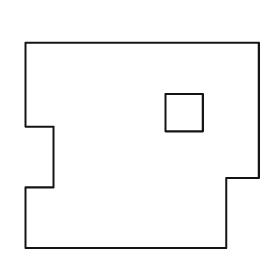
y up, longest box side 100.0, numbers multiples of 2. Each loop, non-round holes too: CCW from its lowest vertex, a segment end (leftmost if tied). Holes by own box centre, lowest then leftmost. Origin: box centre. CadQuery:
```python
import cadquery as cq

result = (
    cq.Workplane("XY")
    .moveTo(-50.0, -44.0)
    .lineTo(36.0, -44.0)
    .lineTo(36.0, -14.0)
    .lineTo(50.0, -14.0)
    .lineTo(50.0, 44.0)
    .lineTo(-50.0, 44.0)
    .lineTo(-50.0, 8.0)
    .lineTo(-38.0, 8.0)
    .lineTo(-38.0, -18.0)
    .lineTo(-50.0, -18.0)
    .close()
    .moveTo(10.0, 6.0)
    .lineTo(26.0, 6.0)
    .lineTo(26.0, 22.0)
    .lineTo(10.0, 22.0)
    .close()
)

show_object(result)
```